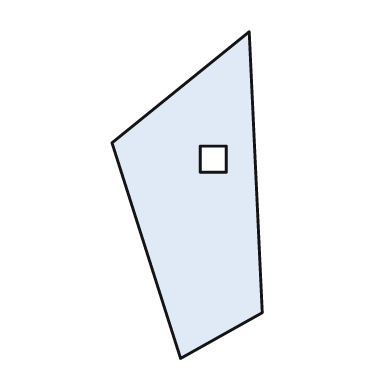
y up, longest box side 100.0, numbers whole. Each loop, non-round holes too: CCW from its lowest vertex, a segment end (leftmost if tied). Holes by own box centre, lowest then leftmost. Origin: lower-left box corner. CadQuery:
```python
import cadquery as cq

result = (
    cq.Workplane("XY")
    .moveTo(21.0, 0.0)
    .lineTo(46.0, 14.0)
    .lineTo(42.0, 100.0)
    .lineTo(0.0, 66.0)
    .close()
    .moveTo(27.0, 57.0)
    .lineTo(35.0, 57.0)
    .lineTo(35.0, 65.0)
    .lineTo(27.0, 65.0)
    .close()
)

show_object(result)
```